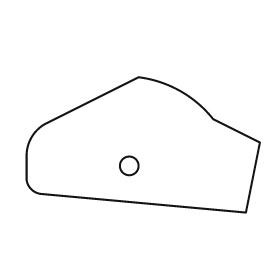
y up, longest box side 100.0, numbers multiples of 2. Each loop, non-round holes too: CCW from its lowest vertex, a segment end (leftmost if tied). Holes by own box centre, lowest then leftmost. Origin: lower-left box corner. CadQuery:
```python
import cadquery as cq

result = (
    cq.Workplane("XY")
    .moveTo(94.0, 0.0)
    .lineTo(100.0, 30.0)
    .lineTo(80.0, 40.0)
    .threePointArc((66.0, 52.0), (48.0, 58.0))
    .lineTo(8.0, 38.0)
    .threePointArc((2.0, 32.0), (0.0, 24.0))
    .lineTo(0.0, 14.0)
    .threePointArc((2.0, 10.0), (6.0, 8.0))
    .close()
    .moveTo(44.0, 20.0)
    .circle(4.0)
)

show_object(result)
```